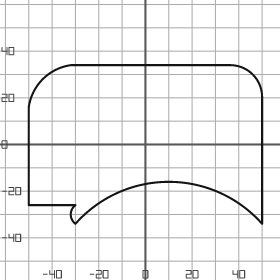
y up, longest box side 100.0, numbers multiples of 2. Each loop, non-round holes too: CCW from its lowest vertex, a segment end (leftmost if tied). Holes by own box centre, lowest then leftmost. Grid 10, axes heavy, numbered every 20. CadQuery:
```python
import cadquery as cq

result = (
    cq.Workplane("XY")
    .moveTo(-30.0, -34.0)
    .threePointArc((10.0, -16.0), (50.0, -34.0))
    .lineTo(50.0, 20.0)
    .threePointArc((46.0, 30.0), (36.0, 34.0))
    .lineTo(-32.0, 34.0)
    .threePointArc((-44.0, 28.0), (-50.0, 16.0))
    .lineTo(-50.0, -26.0)
    .lineTo(-30.0, -26.0)
    .threePointArc((-32.0, -30.0), (-30.0, -34.0))
    .close()
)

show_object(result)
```